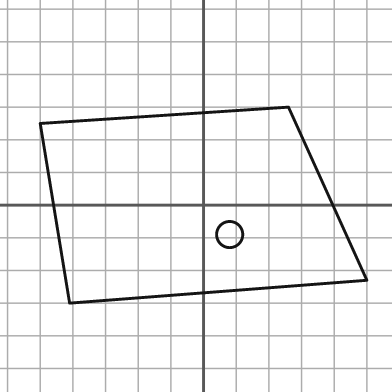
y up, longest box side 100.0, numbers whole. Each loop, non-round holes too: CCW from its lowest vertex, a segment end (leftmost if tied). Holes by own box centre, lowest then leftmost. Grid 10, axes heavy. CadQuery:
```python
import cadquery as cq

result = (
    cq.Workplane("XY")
    .moveTo(-41.0, -30.0)
    .lineTo(50.0, -23.0)
    .lineTo(26.0, 30.0)
    .lineTo(-50.0, 25.0)
    .close()
    .moveTo(8.0, -9.0)
    .circle(4.0)
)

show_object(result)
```